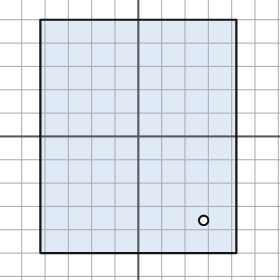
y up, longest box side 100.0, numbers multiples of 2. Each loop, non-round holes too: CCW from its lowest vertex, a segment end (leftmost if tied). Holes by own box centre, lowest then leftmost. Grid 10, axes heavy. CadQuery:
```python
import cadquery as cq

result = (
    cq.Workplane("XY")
    .moveTo(-42.0, -50.0)
    .lineTo(42.0, -50.0)
    .lineTo(42.0, 50.0)
    .lineTo(-42.0, 50.0)
    .close()
    .moveTo(28.0, -36.0)
    .circle(2.0)
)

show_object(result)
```